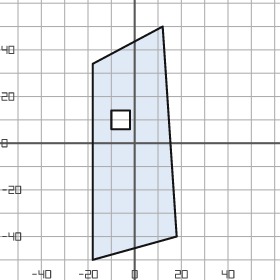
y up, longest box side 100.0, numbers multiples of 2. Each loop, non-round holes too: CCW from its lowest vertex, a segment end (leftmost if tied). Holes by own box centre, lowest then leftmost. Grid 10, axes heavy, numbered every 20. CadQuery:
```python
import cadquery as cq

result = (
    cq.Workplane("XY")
    .moveTo(-18.0, -50.0)
    .lineTo(18.0, -40.0)
    .lineTo(12.0, 50.0)
    .lineTo(-18.0, 34.0)
    .close()
    .moveTo(-10.0, 6.0)
    .lineTo(-2.0, 6.0)
    .lineTo(-2.0, 14.0)
    .lineTo(-10.0, 14.0)
    .close()
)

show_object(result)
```